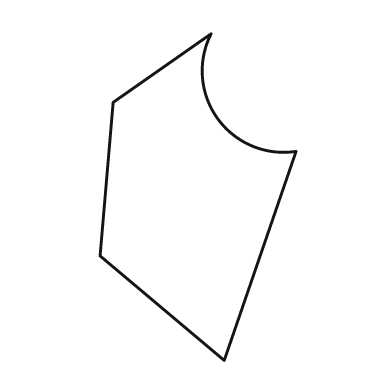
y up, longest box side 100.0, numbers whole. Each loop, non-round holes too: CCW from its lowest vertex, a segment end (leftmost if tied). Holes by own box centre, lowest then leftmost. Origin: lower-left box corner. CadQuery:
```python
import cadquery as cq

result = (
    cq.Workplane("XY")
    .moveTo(38.0, 0.0)
    .lineTo(60.0, 64.0)
    .threePointArc((36.0, 74.0), (34.0, 100.0))
    .lineTo(4.0, 79.0)
    .lineTo(0.0, 32.0)
    .close()
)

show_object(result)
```